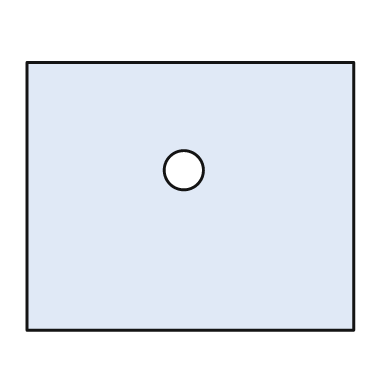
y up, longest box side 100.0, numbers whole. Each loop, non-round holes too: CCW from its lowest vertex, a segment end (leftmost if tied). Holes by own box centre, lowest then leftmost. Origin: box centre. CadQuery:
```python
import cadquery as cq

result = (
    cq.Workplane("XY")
    .moveTo(-50.0, -41.0)
    .lineTo(50.0, -41.0)
    .lineTo(50.0, 41.0)
    .lineTo(-50.0, 41.0)
    .close()
    .moveTo(-2.0, 8.0)
    .circle(6.0)
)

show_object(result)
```